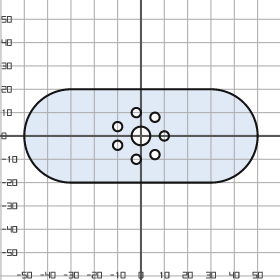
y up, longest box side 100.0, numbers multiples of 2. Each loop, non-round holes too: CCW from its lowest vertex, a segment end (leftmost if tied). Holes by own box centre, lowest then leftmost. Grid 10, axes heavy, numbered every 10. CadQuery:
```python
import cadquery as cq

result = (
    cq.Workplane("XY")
    .moveTo(-30.0, -20.0)
    .lineTo(30.0, -20.0)
    .threePointArc((50.0, 0.0), (30.0, 20.0))
    .lineTo(-30.0, 20.0)
    .threePointArc((-50.0, 0.0), (-30.0, -20.0))
    .close()
    .moveTo(-2.0, -10.0)
    .circle(2.0)
    .moveTo(6.0, -8.0)
    .circle(2.0)
    .moveTo(-10.0, -4.0)
    .circle(2.0)
    .moveTo(0.0, 0.0)
    .circle(4.0)
    .moveTo(10.0, 0.0)
    .circle(2.0)
    .moveTo(-10.0, 4.0)
    .circle(2.0)
    .moveTo(6.0, 8.0)
    .circle(2.0)
    .moveTo(-2.0, 10.0)
    .circle(2.0)
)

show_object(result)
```